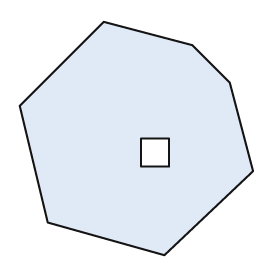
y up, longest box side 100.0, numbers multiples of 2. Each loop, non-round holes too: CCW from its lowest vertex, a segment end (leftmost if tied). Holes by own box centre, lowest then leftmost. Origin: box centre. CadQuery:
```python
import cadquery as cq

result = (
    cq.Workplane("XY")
    .moveTo(12.0, -50.0)
    .lineTo(50.0, -14.0)
    .lineTo(40.0, 24.0)
    .lineTo(24.0, 40.0)
    .lineTo(-14.0, 50.0)
    .lineTo(-50.0, 14.0)
    .lineTo(-38.0, -36.0)
    .close()
    .moveTo(2.0, -12.0)
    .lineTo(14.0, -12.0)
    .lineTo(14.0, 0.0)
    .lineTo(2.0, 0.0)
    .close()
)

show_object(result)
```